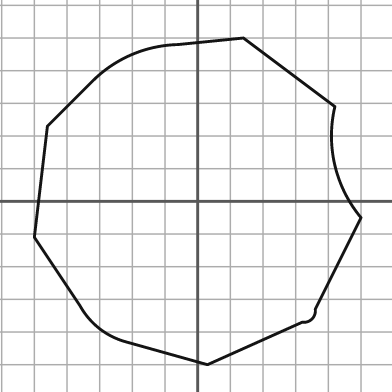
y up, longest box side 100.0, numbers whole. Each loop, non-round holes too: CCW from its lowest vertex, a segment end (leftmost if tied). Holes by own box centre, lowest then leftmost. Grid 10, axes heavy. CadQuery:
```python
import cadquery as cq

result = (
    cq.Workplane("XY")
    .moveTo(3.0, -50.0)
    .lineTo(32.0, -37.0)
    .threePointArc((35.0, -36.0), (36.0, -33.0))
    .lineTo(50.0, -5.0)
    .threePointArc((42.0, 11.0), (42.0, 29.0))
    .lineTo(14.0, 50.0)
    .lineTo(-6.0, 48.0)
    .threePointArc((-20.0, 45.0), (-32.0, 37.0))
    .lineTo(-46.0, 23.0)
    .lineTo(-50.0, -11.0)
    .lineTo(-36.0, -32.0)
    .threePointArc((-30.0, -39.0), (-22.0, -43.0))
    .close()
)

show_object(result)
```